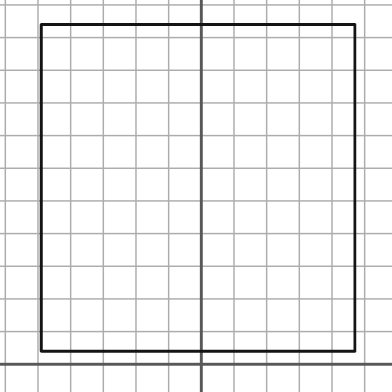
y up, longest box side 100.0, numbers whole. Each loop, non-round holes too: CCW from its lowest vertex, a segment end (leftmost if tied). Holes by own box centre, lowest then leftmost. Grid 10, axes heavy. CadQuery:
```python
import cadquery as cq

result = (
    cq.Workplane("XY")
    .moveTo(-49.0, 4.0)
    .lineTo(47.0, 4.0)
    .lineTo(47.0, 104.0)
    .lineTo(-49.0, 104.0)
    .close()
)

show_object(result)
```